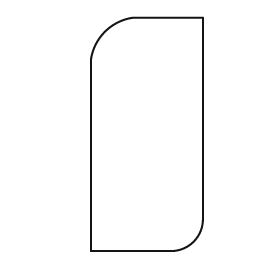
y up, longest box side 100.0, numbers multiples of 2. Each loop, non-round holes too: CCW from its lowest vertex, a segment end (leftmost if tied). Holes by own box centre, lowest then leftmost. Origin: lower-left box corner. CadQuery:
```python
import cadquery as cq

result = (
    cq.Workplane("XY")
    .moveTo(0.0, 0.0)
    .lineTo(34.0, 0.0)
    .threePointArc((44.0, 4.0), (48.0, 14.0))
    .lineTo(48.0, 100.0)
    .lineTo(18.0, 100.0)
    .threePointArc((6.0, 94.0), (0.0, 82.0))
    .close()
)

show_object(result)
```